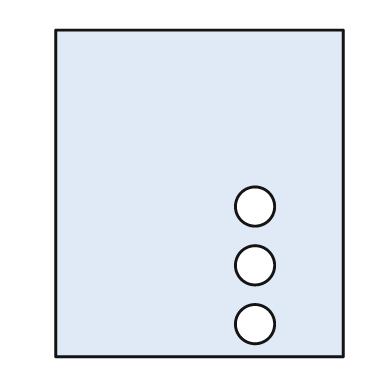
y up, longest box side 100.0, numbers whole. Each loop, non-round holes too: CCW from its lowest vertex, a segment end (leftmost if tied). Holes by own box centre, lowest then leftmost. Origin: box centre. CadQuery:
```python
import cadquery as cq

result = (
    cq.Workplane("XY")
    .moveTo(-44.0, -50.0)
    .lineTo(44.0, -50.0)
    .lineTo(44.0, 50.0)
    .lineTo(-44.0, 50.0)
    .close()
    .moveTo(17.0, -40.0)
    .circle(6.0)
    .moveTo(17.0, -22.0)
    .circle(6.0)
    .moveTo(17.0, -4.0)
    .circle(6.0)
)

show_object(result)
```